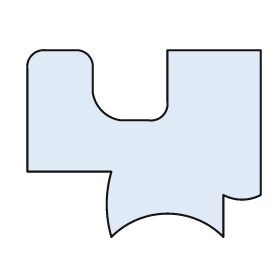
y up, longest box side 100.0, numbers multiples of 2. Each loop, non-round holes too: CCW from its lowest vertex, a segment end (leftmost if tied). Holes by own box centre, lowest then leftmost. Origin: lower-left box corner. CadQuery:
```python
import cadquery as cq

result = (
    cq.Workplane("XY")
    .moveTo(36.0, 0.0)
    .threePointArc((60.0, 10.0), (84.0, 0.0))
    .lineTo(84.0, 18.0)
    .threePointArc((92.0, 16.0), (100.0, 18.0))
    .lineTo(100.0, 80.0)
    .lineTo(60.0, 80.0)
    .lineTo(60.0, 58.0)
    .threePointArc((58.0, 52.0), (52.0, 50.0))
    .lineTo(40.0, 50.0)
    .threePointArc((32.0, 54.0), (28.0, 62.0))
    .lineTo(28.0, 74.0)
    .threePointArc((26.0, 78.0), (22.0, 80.0))
    .lineTo(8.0, 80.0)
    .threePointArc((2.0, 78.0), (0.0, 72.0))
    .lineTo(0.0, 28.0)
    .lineTo(36.0, 28.0)
    .threePointArc((34.0, 14.0), (36.0, 0.0))
    .close()
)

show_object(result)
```